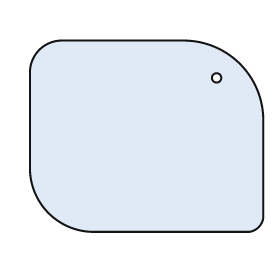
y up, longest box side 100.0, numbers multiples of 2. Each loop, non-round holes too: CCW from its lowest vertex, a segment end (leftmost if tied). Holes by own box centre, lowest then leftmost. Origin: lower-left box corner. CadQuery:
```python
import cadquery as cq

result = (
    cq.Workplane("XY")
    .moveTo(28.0, 0.0)
    .lineTo(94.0, 0.0)
    .threePointArc((98.0, 2.0), (100.0, 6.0))
    .lineTo(100.0, 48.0)
    .threePointArc((90.0, 72.0), (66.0, 82.0))
    .lineTo(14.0, 82.0)
    .threePointArc((4.0, 78.0), (0.0, 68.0))
    .lineTo(0.0, 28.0)
    .threePointArc((8.0, 8.0), (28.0, 0.0))
    .close()
    .moveTo(80.0, 66.0)
    .circle(2.0)
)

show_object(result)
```